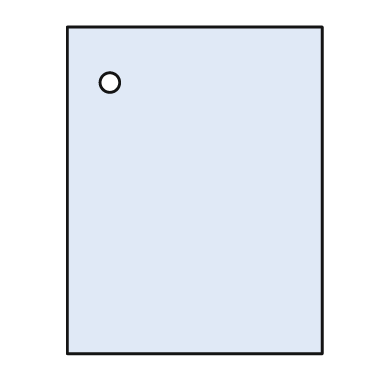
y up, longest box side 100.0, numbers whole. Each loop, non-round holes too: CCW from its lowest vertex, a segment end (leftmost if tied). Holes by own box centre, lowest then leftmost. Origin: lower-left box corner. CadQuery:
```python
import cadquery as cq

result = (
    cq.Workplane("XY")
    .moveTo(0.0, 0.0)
    .lineTo(78.0, 0.0)
    .lineTo(78.0, 100.0)
    .lineTo(0.0, 100.0)
    .close()
    .moveTo(13.0, 83.0)
    .circle(3.0)
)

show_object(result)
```